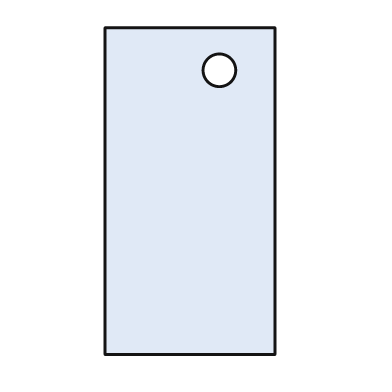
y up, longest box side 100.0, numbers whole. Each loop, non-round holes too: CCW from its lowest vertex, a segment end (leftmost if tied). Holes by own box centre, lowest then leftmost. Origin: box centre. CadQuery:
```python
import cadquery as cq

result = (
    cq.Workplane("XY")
    .moveTo(-26.0, -50.0)
    .lineTo(26.0, -50.0)
    .lineTo(26.0, 50.0)
    .lineTo(-26.0, 50.0)
    .close()
    .moveTo(9.0, 37.0)
    .circle(5.0)
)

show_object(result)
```